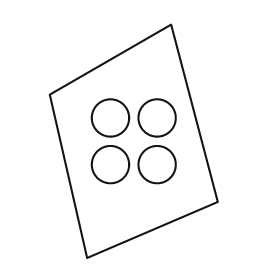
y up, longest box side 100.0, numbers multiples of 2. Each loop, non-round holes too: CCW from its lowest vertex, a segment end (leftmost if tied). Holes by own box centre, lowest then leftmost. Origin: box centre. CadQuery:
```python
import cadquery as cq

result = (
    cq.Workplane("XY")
    .moveTo(-20.0, -50.0)
    .lineTo(36.0, -26.0)
    .lineTo(16.0, 50.0)
    .lineTo(-36.0, 20.0)
    .close()
    .moveTo(-10.0, -10.0)
    .circle(8.0)
    .moveTo(10.0, -10.0)
    .circle(8.0)
    .moveTo(-10.0, 10.0)
    .circle(8.0)
    .moveTo(10.0, 10.0)
    .circle(8.0)
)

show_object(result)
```